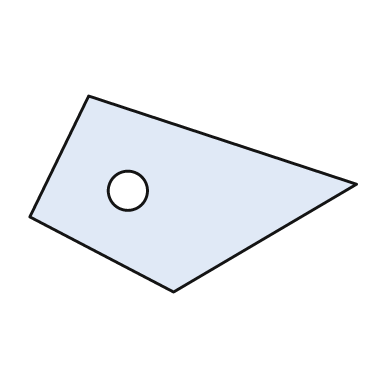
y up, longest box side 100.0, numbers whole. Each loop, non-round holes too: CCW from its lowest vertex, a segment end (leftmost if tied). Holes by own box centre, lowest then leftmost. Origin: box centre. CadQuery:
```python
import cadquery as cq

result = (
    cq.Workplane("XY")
    .moveTo(-6.0, -30.0)
    .lineTo(50.0, 3.0)
    .lineTo(-32.0, 30.0)
    .lineTo(-50.0, -7.0)
    .close()
    .moveTo(-20.0, 1.0)
    .circle(6.0)
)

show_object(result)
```